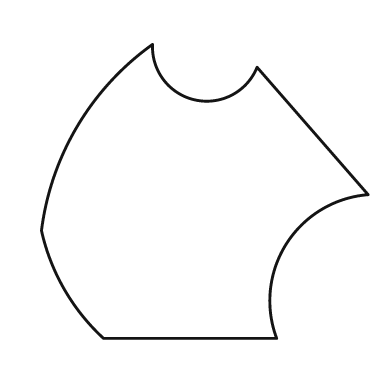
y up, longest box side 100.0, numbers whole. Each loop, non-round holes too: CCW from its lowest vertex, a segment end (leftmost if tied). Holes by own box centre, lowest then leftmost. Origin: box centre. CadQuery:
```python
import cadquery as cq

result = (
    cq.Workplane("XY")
    .moveTo(-31.0, -45.0)
    .lineTo(22.0, -45.0)
    .threePointArc((25.0, -16.0), (50.0, -1.0))
    .lineTo(16.0, 38.0)
    .threePointArc((-3.0, 28.0), (-16.0, 45.0))
    .threePointArc((-39.0, 20.0), (-50.0, -12.0))
    .threePointArc((-43.0, -30.0), (-31.0, -45.0))
    .close()
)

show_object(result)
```